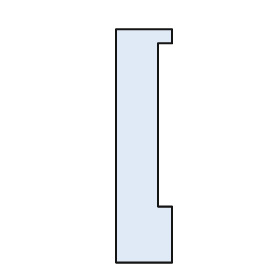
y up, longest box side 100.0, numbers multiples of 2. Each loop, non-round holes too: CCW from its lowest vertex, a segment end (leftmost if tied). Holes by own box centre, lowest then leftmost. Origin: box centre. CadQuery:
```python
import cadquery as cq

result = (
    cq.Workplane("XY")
    .moveTo(-12.0, -50.0)
    .lineTo(12.0, -50.0)
    .lineTo(12.0, -26.0)
    .lineTo(6.0, -26.0)
    .lineTo(6.0, 44.0)
    .lineTo(12.0, 44.0)
    .lineTo(12.0, 50.0)
    .lineTo(-12.0, 50.0)
    .close()
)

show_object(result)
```